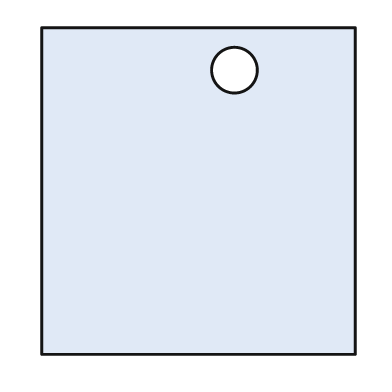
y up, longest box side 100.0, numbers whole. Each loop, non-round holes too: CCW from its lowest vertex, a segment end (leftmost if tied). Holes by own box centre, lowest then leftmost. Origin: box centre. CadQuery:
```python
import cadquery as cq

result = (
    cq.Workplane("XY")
    .moveTo(-48.0, -50.0)
    .lineTo(48.0, -50.0)
    .lineTo(48.0, 50.0)
    .lineTo(-48.0, 50.0)
    .close()
    .moveTo(11.0, 37.0)
    .circle(7.0)
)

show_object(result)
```